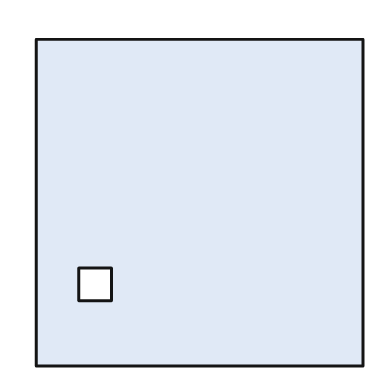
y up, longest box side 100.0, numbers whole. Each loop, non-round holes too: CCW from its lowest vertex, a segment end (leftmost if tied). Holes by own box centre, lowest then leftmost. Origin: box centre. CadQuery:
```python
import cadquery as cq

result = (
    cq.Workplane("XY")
    .moveTo(-50.0, -50.0)
    .lineTo(50.0, -50.0)
    .lineTo(50.0, 50.0)
    .lineTo(-50.0, 50.0)
    .close()
    .moveTo(-37.0, -30.0)
    .lineTo(-27.0, -30.0)
    .lineTo(-27.0, -20.0)
    .lineTo(-37.0, -20.0)
    .close()
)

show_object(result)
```